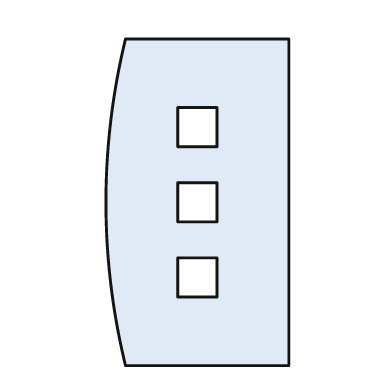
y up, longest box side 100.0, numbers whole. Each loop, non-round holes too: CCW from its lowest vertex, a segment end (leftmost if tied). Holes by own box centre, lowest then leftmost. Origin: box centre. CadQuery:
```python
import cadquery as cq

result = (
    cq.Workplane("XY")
    .moveTo(-22.0, -50.0)
    .lineTo(28.0, -50.0)
    .lineTo(28.0, 50.0)
    .lineTo(-22.0, 50.0)
    .threePointArc((-28.0, 0.0), (-22.0, -50.0))
    .close()
    .moveTo(-6.0, -29.0)
    .lineTo(6.0, -29.0)
    .lineTo(6.0, -17.0)
    .lineTo(-6.0, -17.0)
    .close()
    .moveTo(-6.0, -6.0)
    .lineTo(6.0, -6.0)
    .lineTo(6.0, 6.0)
    .lineTo(-6.0, 6.0)
    .close()
    .moveTo(-6.0, 17.0)
    .lineTo(6.0, 17.0)
    .lineTo(6.0, 29.0)
    .lineTo(-6.0, 29.0)
    .close()
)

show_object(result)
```